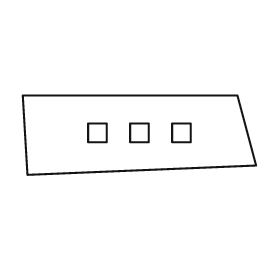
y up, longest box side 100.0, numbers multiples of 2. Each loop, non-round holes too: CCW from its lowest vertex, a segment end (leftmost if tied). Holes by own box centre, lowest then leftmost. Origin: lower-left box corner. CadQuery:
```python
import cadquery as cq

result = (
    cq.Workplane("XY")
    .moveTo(2.0, 0.0)
    .lineTo(100.0, 4.0)
    .lineTo(92.0, 34.0)
    .lineTo(0.0, 34.0)
    .close()
    .moveTo(28.0, 14.0)
    .lineTo(36.0, 14.0)
    .lineTo(36.0, 22.0)
    .lineTo(28.0, 22.0)
    .close()
    .moveTo(46.0, 14.0)
    .lineTo(54.0, 14.0)
    .lineTo(54.0, 22.0)
    .lineTo(46.0, 22.0)
    .close()
    .moveTo(64.0, 14.0)
    .lineTo(72.0, 14.0)
    .lineTo(72.0, 22.0)
    .lineTo(64.0, 22.0)
    .close()
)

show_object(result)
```